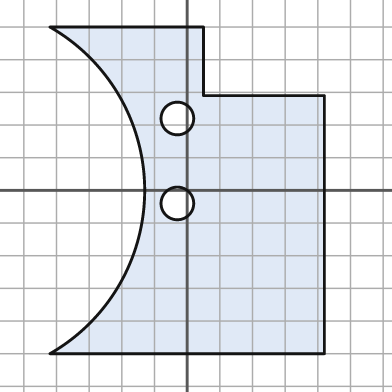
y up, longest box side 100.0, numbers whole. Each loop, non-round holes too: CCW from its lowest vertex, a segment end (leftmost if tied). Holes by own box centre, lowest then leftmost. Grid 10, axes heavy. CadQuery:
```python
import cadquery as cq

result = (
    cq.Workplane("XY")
    .moveTo(-42.0, -50.0)
    .lineTo(42.0, -50.0)
    .lineTo(42.0, 29.0)
    .lineTo(5.0, 29.0)
    .lineTo(5.0, 50.0)
    .lineTo(-42.0, 50.0)
    .threePointArc((-13.0, 0.0), (-42.0, -50.0))
    .close()
    .moveTo(-3.0, -4.0)
    .circle(5.0)
    .moveTo(-3.0, 22.0)
    .circle(5.0)
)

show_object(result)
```